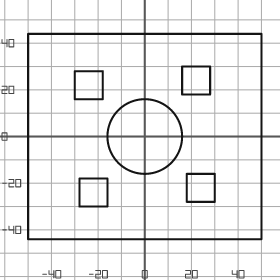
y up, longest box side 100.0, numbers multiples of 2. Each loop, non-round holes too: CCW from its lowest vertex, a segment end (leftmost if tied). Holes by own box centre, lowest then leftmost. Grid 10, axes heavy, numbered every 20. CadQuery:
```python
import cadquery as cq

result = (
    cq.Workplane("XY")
    .moveTo(-50.0, -44.0)
    .lineTo(50.0, -44.0)
    .lineTo(50.0, 44.0)
    .lineTo(-50.0, 44.0)
    .close()
    .moveTo(-28.0, -30.0)
    .lineTo(-16.0, -30.0)
    .lineTo(-16.0, -18.0)
    .lineTo(-28.0, -18.0)
    .close()
    .moveTo(18.0, -28.0)
    .lineTo(30.0, -28.0)
    .lineTo(30.0, -16.0)
    .lineTo(18.0, -16.0)
    .close()
    .moveTo(0.0, 0.0)
    .circle(16.0)
    .moveTo(-30.0, 16.0)
    .lineTo(-18.0, 16.0)
    .lineTo(-18.0, 28.0)
    .lineTo(-30.0, 28.0)
    .close()
    .moveTo(16.0, 18.0)
    .lineTo(28.0, 18.0)
    .lineTo(28.0, 30.0)
    .lineTo(16.0, 30.0)
    .close()
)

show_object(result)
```